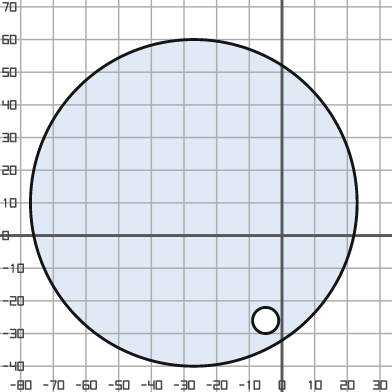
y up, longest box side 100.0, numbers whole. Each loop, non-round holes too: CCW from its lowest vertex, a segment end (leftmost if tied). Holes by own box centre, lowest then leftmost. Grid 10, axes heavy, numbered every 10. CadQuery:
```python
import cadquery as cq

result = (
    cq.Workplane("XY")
    .moveTo(-27.0, 10.0)
    .circle(50.0)
    .moveTo(-5.0, -26.0)
    .circle(4.0)
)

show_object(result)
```